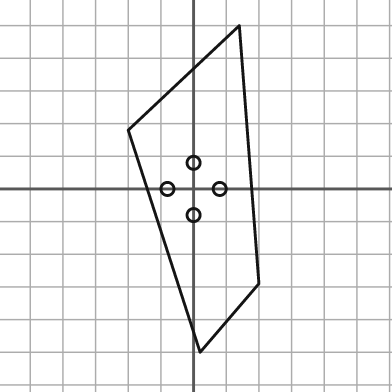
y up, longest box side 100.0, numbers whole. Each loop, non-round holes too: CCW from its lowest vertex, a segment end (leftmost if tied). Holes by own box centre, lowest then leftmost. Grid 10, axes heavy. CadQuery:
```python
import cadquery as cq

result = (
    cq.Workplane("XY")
    .moveTo(2.0, -50.0)
    .lineTo(20.0, -29.0)
    .lineTo(14.0, 50.0)
    .lineTo(-20.0, 18.0)
    .close()
    .moveTo(0.0, -8.0)
    .circle(2.0)
    .moveTo(-8.0, 0.0)
    .circle(2.0)
    .moveTo(8.0, 0.0)
    .circle(2.0)
    .moveTo(0.0, 8.0)
    .circle(2.0)
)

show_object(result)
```